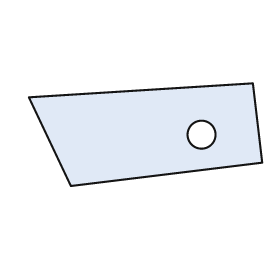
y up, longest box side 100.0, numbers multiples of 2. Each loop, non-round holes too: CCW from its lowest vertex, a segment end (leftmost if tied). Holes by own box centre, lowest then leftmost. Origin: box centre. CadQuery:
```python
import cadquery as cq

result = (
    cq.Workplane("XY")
    .moveTo(-32.0, -22.0)
    .lineTo(50.0, -12.0)
    .lineTo(46.0, 22.0)
    .lineTo(-50.0, 16.0)
    .close()
    .moveTo(24.0, 0.0)
    .circle(6.0)
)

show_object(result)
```